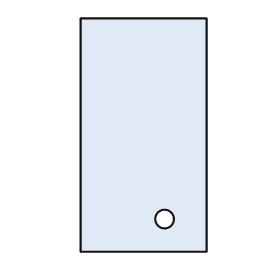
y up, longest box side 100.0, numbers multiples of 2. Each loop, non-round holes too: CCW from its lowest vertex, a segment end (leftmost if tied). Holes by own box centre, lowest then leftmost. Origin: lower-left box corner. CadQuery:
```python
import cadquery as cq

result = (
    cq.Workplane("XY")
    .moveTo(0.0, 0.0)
    .lineTo(54.0, 0.0)
    .lineTo(54.0, 100.0)
    .lineTo(0.0, 100.0)
    .close()
    .moveTo(36.0, 14.0)
    .circle(4.0)
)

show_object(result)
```